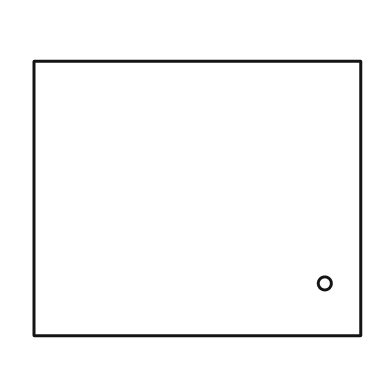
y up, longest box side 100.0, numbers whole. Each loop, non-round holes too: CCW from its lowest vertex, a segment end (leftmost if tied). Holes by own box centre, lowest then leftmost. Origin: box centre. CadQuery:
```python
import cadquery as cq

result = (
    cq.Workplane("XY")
    .moveTo(-50.0, -42.0)
    .lineTo(50.0, -42.0)
    .lineTo(50.0, 42.0)
    .lineTo(-50.0, 42.0)
    .close()
    .moveTo(39.0, -26.0)
    .circle(2.0)
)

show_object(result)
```